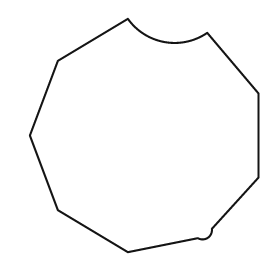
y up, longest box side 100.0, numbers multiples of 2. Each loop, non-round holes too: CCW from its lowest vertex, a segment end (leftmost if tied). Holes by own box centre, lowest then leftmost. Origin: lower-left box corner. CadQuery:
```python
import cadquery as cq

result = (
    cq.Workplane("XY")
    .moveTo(42.0, 0.0)
    .lineTo(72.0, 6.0)
    .threePointArc((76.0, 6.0), (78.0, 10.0))
    .lineTo(98.0, 32.0)
    .lineTo(98.0, 68.0)
    .lineTo(76.0, 94.0)
    .threePointArc((58.0, 90.0), (42.0, 100.0))
    .lineTo(12.0, 82.0)
    .lineTo(0.0, 50.0)
    .lineTo(12.0, 18.0)
    .close()
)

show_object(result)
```